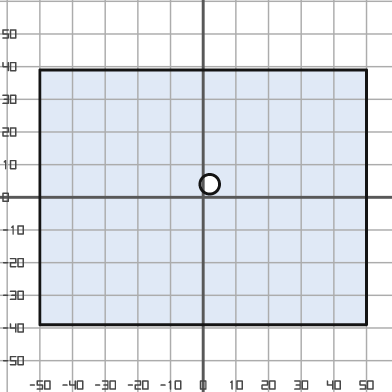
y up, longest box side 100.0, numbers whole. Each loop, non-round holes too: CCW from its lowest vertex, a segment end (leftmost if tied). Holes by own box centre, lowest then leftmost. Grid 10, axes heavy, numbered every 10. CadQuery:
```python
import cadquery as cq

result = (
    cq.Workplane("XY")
    .moveTo(-50.0, -39.0)
    .lineTo(50.0, -39.0)
    .lineTo(50.0, 39.0)
    .lineTo(-50.0, 39.0)
    .close()
    .moveTo(2.0, 4.0)
    .circle(3.0)
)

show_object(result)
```